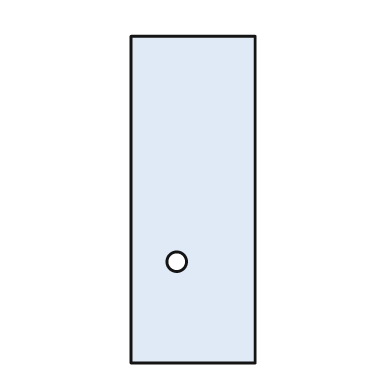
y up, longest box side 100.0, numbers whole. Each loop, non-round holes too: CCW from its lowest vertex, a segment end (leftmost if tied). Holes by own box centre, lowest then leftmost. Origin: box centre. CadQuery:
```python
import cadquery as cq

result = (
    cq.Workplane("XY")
    .moveTo(-19.0, -50.0)
    .lineTo(19.0, -50.0)
    .lineTo(19.0, 50.0)
    .lineTo(-19.0, 50.0)
    .close()
    .moveTo(-5.0, -19.0)
    .circle(3.0)
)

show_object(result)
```